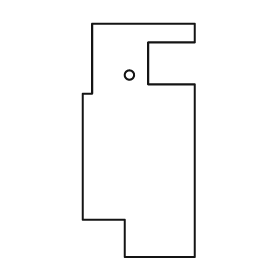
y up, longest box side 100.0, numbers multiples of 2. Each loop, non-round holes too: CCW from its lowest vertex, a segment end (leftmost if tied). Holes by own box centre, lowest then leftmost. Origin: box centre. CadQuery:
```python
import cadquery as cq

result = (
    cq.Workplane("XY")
    .moveTo(-6.0, -50.0)
    .lineTo(24.0, -50.0)
    .lineTo(24.0, 24.0)
    .lineTo(4.0, 24.0)
    .lineTo(4.0, 42.0)
    .lineTo(24.0, 42.0)
    .lineTo(24.0, 50.0)
    .lineTo(-20.0, 50.0)
    .lineTo(-20.0, 20.0)
    .lineTo(-24.0, 20.0)
    .lineTo(-24.0, -34.0)
    .lineTo(-6.0, -34.0)
    .close()
    .moveTo(-4.0, 28.0)
    .circle(2.0)
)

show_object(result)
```